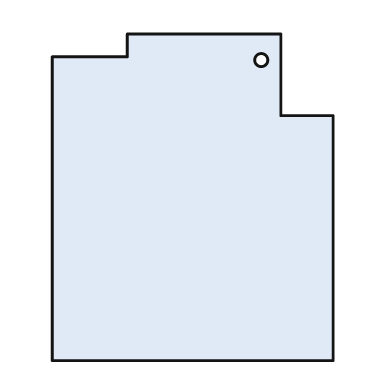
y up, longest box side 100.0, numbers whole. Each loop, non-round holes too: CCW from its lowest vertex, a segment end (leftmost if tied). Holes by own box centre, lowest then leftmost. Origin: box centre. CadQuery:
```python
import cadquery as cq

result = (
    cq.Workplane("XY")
    .moveTo(-43.0, -50.0)
    .lineTo(43.0, -50.0)
    .lineTo(43.0, 25.0)
    .lineTo(27.0, 25.0)
    .lineTo(27.0, 50.0)
    .lineTo(-20.0, 50.0)
    .lineTo(-20.0, 43.0)
    .lineTo(-43.0, 43.0)
    .close()
    .moveTo(21.0, 42.0)
    .circle(2.0)
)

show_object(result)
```